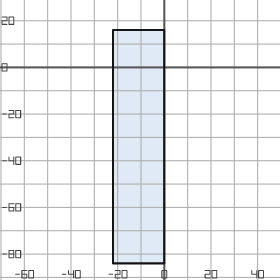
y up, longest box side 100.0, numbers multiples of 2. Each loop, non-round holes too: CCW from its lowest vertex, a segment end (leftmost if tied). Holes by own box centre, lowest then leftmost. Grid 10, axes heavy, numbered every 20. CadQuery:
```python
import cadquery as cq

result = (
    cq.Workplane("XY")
    .moveTo(-22.0, -84.0)
    .lineTo(0.0, -84.0)
    .lineTo(0.0, 16.0)
    .lineTo(-22.0, 16.0)
    .close()
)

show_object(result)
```